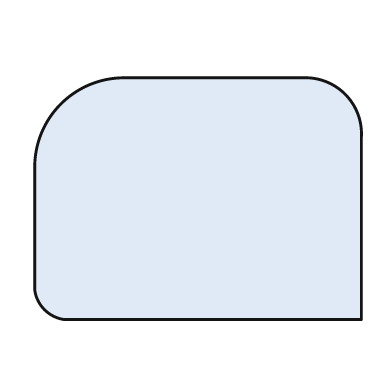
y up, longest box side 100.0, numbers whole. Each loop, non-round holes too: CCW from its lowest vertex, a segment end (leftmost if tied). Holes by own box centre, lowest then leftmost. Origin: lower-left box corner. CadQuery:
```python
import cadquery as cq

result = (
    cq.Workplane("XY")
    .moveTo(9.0, 0.0)
    .lineTo(100.0, 0.0)
    .lineTo(100.0, 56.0)
    .threePointArc((95.0, 69.0), (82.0, 74.0))
    .lineTo(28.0, 74.0)
    .threePointArc((8.0, 66.0), (0.0, 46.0))
    .lineTo(0.0, 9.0)
    .threePointArc((3.0, 3.0), (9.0, 0.0))
    .close()
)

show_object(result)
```